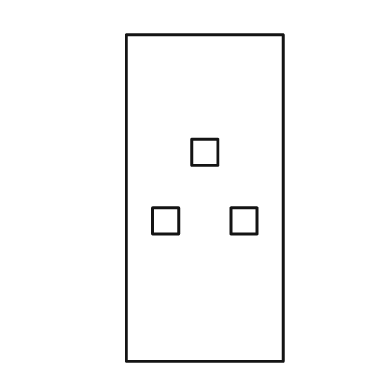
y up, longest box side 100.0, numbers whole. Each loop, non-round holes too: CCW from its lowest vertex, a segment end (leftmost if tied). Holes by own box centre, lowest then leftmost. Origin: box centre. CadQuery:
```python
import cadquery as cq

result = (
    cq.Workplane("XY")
    .moveTo(-24.0, -50.0)
    .lineTo(24.0, -50.0)
    .lineTo(24.0, 50.0)
    .lineTo(-24.0, 50.0)
    .close()
    .moveTo(-16.0, -11.0)
    .lineTo(-8.0, -11.0)
    .lineTo(-8.0, -3.0)
    .lineTo(-16.0, -3.0)
    .close()
    .moveTo(8.0, -11.0)
    .lineTo(16.0, -11.0)
    .lineTo(16.0, -3.0)
    .lineTo(8.0, -3.0)
    .close()
    .moveTo(-4.0, 10.0)
    .lineTo(4.0, 10.0)
    .lineTo(4.0, 18.0)
    .lineTo(-4.0, 18.0)
    .close()
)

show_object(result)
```